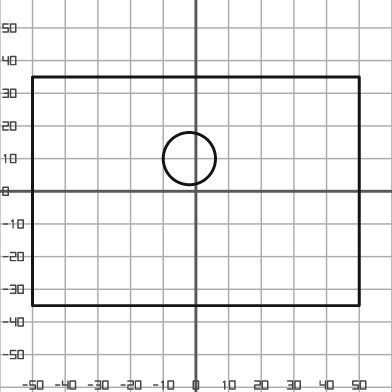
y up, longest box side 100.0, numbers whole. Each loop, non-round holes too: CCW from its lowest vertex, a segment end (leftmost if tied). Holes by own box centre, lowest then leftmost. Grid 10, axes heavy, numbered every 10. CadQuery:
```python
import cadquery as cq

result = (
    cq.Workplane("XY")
    .moveTo(-50.0, -35.0)
    .lineTo(50.0, -35.0)
    .lineTo(50.0, 35.0)
    .lineTo(-50.0, 35.0)
    .close()
    .moveTo(-2.0, 10.0)
    .circle(8.0)
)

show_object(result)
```